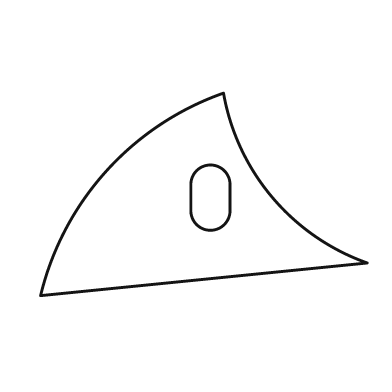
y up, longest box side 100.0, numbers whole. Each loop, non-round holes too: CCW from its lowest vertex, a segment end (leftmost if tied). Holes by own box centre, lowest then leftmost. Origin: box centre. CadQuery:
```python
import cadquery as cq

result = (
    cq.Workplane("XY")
    .moveTo(-50.0, -31.0)
    .lineTo(50.0, -21.0)
    .threePointArc((21.0, -1.0), (6.0, 31.0))
    .threePointArc((-30.0, 7.0), (-50.0, -31.0))
    .close()
    .moveTo(-4.0, -5.0)
    .threePointArc((2.0, -11.0), (8.0, -5.0))
    .lineTo(8.0, 3.0)
    .threePointArc((2.0, 9.0), (-4.0, 3.0))
    .close()
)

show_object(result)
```